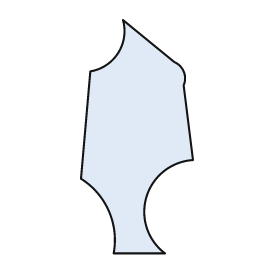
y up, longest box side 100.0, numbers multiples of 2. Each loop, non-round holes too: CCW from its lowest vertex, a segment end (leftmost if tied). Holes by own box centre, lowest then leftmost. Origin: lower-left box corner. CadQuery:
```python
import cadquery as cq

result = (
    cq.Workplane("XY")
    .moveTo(14.0, 0.0)
    .lineTo(36.0, 0.0)
    .threePointArc((28.0, 24.0), (48.0, 40.0))
    .lineTo(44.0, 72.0)
    .threePointArc((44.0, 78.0), (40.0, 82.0))
    .lineTo(18.0, 100.0)
    .threePointArc((16.0, 86.0), (4.0, 78.0))
    .lineTo(0.0, 32.0)
    .threePointArc((12.0, 18.0), (14.0, 0.0))
    .close()
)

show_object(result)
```